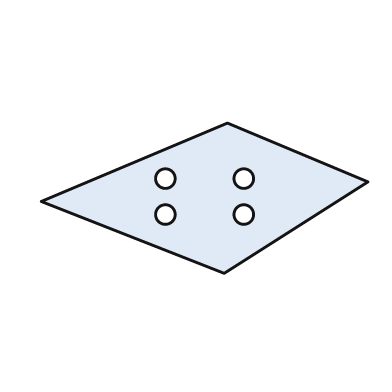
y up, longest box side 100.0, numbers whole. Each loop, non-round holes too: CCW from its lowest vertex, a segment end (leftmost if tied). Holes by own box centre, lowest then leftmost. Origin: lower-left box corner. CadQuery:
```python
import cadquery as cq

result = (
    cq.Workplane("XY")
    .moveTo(56.0, 0.0)
    .lineTo(100.0, 28.0)
    .lineTo(57.0, 46.0)
    .lineTo(0.0, 22.0)
    .close()
    .moveTo(38.0, 18.0)
    .circle(3.0)
    .moveTo(62.0, 18.0)
    .circle(3.0)
    .moveTo(38.0, 29.0)
    .circle(3.0)
    .moveTo(62.0, 29.0)
    .circle(3.0)
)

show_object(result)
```